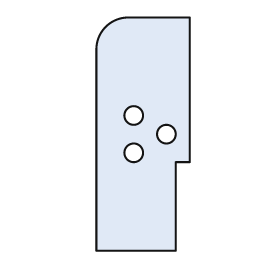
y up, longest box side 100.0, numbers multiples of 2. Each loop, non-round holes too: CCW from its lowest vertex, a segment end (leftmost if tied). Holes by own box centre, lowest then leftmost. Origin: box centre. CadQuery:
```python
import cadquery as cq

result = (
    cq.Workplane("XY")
    .moveTo(-20.0, -50.0)
    .lineTo(14.0, -50.0)
    .lineTo(14.0, -12.0)
    .lineTo(20.0, -12.0)
    .lineTo(20.0, 50.0)
    .lineTo(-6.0, 50.0)
    .threePointArc((-16.0, 46.0), (-20.0, 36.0))
    .close()
    .moveTo(-4.0, -8.0)
    .circle(4.0)
    .moveTo(10.0, 0.0)
    .circle(4.0)
    .moveTo(-4.0, 8.0)
    .circle(4.0)
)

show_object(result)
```